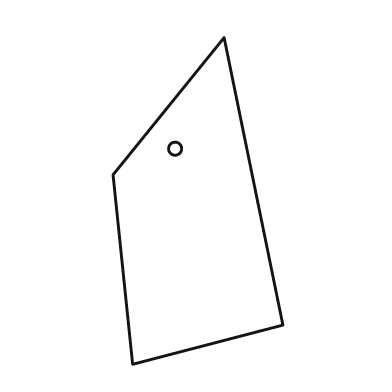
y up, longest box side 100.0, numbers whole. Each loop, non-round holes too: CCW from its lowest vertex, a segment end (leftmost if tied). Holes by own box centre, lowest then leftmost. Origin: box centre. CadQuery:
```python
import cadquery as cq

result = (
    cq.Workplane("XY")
    .moveTo(-20.0, -50.0)
    .lineTo(26.0, -38.0)
    .lineTo(8.0, 50.0)
    .lineTo(-26.0, 8.0)
    .close()
    .moveTo(-7.0, 16.0)
    .circle(2.0)
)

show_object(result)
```